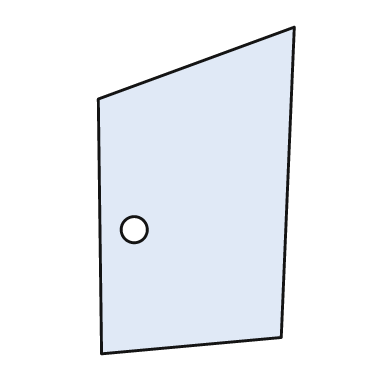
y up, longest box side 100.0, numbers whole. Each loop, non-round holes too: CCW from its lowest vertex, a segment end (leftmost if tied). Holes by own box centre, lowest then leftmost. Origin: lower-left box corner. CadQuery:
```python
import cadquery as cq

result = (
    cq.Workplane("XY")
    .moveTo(1.0, 0.0)
    .lineTo(56.0, 5.0)
    .lineTo(60.0, 100.0)
    .lineTo(0.0, 78.0)
    .close()
    .moveTo(11.0, 38.0)
    .circle(4.0)
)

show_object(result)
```